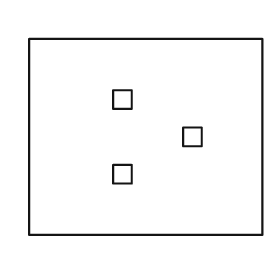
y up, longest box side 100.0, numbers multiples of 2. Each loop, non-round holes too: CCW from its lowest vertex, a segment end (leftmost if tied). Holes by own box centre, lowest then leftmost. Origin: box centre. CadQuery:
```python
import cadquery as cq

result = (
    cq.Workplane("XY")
    .moveTo(-50.0, -42.0)
    .lineTo(50.0, -42.0)
    .lineTo(50.0, 42.0)
    .lineTo(-50.0, 42.0)
    .close()
    .moveTo(-14.0, -20.0)
    .lineTo(-6.0, -20.0)
    .lineTo(-6.0, -12.0)
    .lineTo(-14.0, -12.0)
    .close()
    .moveTo(16.0, -4.0)
    .lineTo(24.0, -4.0)
    .lineTo(24.0, 4.0)
    .lineTo(16.0, 4.0)
    .close()
    .moveTo(-14.0, 12.0)
    .lineTo(-6.0, 12.0)
    .lineTo(-6.0, 20.0)
    .lineTo(-14.0, 20.0)
    .close()
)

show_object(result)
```